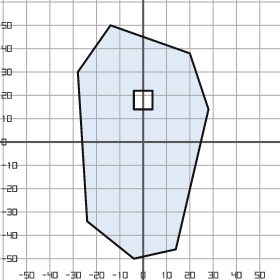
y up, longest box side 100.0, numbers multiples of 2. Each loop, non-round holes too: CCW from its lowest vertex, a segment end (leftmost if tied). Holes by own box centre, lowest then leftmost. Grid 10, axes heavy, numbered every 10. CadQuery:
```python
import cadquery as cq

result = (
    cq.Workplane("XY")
    .moveTo(-4.0, -50.0)
    .lineTo(14.0, -46.0)
    .lineTo(28.0, 14.0)
    .lineTo(20.0, 38.0)
    .lineTo(-14.0, 50.0)
    .lineTo(-28.0, 30.0)
    .lineTo(-24.0, -34.0)
    .close()
    .moveTo(-4.0, 14.0)
    .lineTo(4.0, 14.0)
    .lineTo(4.0, 22.0)
    .lineTo(-4.0, 22.0)
    .close()
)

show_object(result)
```